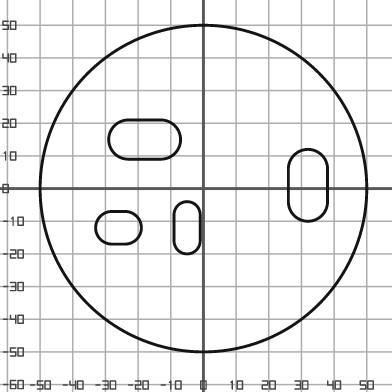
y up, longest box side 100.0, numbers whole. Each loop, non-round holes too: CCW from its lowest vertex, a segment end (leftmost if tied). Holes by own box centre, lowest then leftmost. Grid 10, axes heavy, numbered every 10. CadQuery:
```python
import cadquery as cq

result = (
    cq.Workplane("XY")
    .moveTo(0.0, 0.0)
    .circle(50.0)
    .moveTo(-28.0, -17.0)
    .lineTo(-24.0, -17.0)
    .threePointArc((-19.0, -12.0), (-24.0, -7.0))
    .lineTo(-28.0, -7.0)
    .threePointArc((-33.0, -12.0), (-28.0, -17.0))
    .close()
    .moveTo(-9.0, -16.0)
    .threePointArc((-5.0, -20.0), (-1.0, -16.0))
    .lineTo(-1.0, -8.0)
    .threePointArc((-5.0, -4.0), (-9.0, -8.0))
    .close()
    .moveTo(26.0, -4.0)
    .threePointArc((32.0, -10.0), (38.0, -4.0))
    .lineTo(38.0, 6.0)
    .threePointArc((32.0, 12.0), (26.0, 6.0))
    .close()
    .moveTo(-23.0, 9.0)
    .lineTo(-13.0, 9.0)
    .threePointArc((-7.0, 15.0), (-13.0, 21.0))
    .lineTo(-23.0, 21.0)
    .threePointArc((-29.0, 15.0), (-23.0, 9.0))
    .close()
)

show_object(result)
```